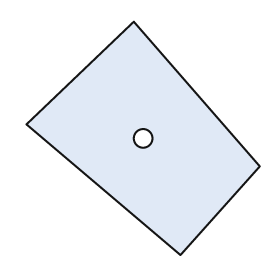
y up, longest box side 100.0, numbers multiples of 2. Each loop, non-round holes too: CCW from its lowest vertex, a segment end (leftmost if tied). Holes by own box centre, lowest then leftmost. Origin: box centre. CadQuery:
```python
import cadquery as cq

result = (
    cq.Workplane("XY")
    .moveTo(16.0, -50.0)
    .lineTo(50.0, -12.0)
    .lineTo(-4.0, 50.0)
    .lineTo(-50.0, 6.0)
    .close()
    .moveTo(0.0, 0.0)
    .circle(4.0)
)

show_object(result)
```